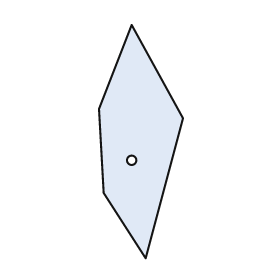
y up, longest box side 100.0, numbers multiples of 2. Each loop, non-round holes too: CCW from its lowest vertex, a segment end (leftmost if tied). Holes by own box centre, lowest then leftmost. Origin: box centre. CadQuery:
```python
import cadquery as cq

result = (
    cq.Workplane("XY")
    .moveTo(2.0, -50.0)
    .lineTo(18.0, 10.0)
    .lineTo(-4.0, 50.0)
    .lineTo(-18.0, 14.0)
    .lineTo(-16.0, -22.0)
    .close()
    .moveTo(-4.0, -8.0)
    .circle(2.0)
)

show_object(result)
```